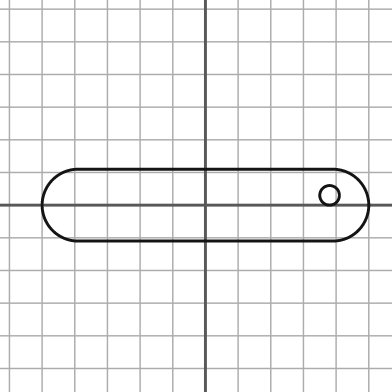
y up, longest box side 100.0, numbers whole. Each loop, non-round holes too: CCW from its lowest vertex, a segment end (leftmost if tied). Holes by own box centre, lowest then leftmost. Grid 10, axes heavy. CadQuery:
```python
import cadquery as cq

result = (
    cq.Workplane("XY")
    .moveTo(-39.0, -11.0)
    .lineTo(39.0, -11.0)
    .threePointArc((50.0, 0.0), (39.0, 11.0))
    .lineTo(-39.0, 11.0)
    .threePointArc((-50.0, 0.0), (-39.0, -11.0))
    .close()
    .moveTo(38.0, 3.0)
    .circle(3.0)
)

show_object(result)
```